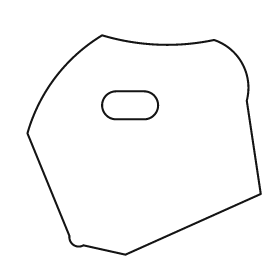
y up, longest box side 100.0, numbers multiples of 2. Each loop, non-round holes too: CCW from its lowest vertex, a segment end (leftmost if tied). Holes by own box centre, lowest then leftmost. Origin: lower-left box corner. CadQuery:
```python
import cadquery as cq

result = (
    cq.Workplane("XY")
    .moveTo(42.0, 0.0)
    .lineTo(100.0, 26.0)
    .lineTo(94.0, 66.0)
    .threePointArc((92.0, 82.0), (80.0, 92.0))
    .threePointArc((56.0, 90.0), (32.0, 94.0))
    .threePointArc((12.0, 76.0), (0.0, 52.0))
    .lineTo(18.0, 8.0)
    .threePointArc((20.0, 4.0), (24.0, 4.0))
    .close()
    .moveTo(38.0, 58.0)
    .lineTo(50.0, 58.0)
    .threePointArc((56.0, 64.0), (50.0, 70.0))
    .lineTo(38.0, 70.0)
    .threePointArc((32.0, 64.0), (38.0, 58.0))
    .close()
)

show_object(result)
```